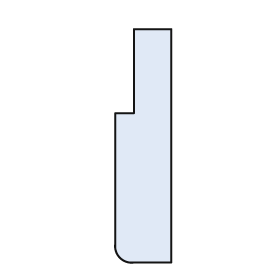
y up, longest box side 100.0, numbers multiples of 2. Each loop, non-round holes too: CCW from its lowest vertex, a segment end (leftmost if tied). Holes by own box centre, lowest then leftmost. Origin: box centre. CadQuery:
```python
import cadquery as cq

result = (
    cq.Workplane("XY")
    .moveTo(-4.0, -50.0)
    .lineTo(12.0, -50.0)
    .lineTo(12.0, 50.0)
    .lineTo(-4.0, 50.0)
    .lineTo(-4.0, 14.0)
    .lineTo(-12.0, 14.0)
    .lineTo(-12.0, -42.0)
    .threePointArc((-10.0, -48.0), (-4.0, -50.0))
    .close()
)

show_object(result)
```